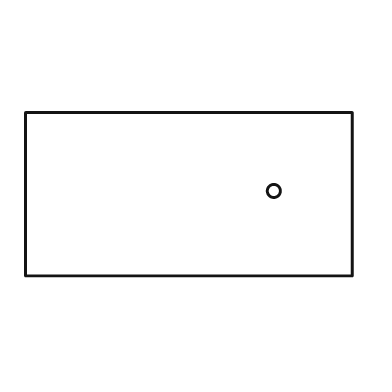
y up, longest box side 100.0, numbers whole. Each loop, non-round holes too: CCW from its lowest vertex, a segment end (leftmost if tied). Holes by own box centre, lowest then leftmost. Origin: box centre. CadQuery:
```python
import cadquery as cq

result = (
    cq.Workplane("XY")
    .moveTo(-50.0, -25.0)
    .lineTo(50.0, -25.0)
    .lineTo(50.0, 25.0)
    .lineTo(-50.0, 25.0)
    .close()
    .moveTo(26.0, 1.0)
    .circle(2.0)
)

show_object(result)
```